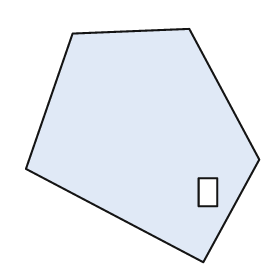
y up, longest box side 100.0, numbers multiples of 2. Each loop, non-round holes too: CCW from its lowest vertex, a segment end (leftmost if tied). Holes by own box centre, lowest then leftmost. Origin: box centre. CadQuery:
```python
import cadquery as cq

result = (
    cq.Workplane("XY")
    .moveTo(26.0, -50.0)
    .lineTo(50.0, -6.0)
    .lineTo(20.0, 50.0)
    .lineTo(-30.0, 48.0)
    .lineTo(-50.0, -10.0)
    .close()
    .moveTo(24.0, -26.0)
    .lineTo(32.0, -26.0)
    .lineTo(32.0, -14.0)
    .lineTo(24.0, -14.0)
    .close()
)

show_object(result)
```